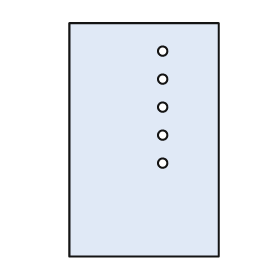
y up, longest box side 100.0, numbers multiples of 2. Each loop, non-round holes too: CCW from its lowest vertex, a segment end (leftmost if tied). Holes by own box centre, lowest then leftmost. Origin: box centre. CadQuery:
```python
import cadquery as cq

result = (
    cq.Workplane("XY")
    .moveTo(-32.0, -50.0)
    .lineTo(32.0, -50.0)
    .lineTo(32.0, 50.0)
    .lineTo(-32.0, 50.0)
    .close()
    .moveTo(8.0, -10.0)
    .circle(2.0)
    .moveTo(8.0, 2.0)
    .circle(2.0)
    .moveTo(8.0, 14.0)
    .circle(2.0)
    .moveTo(8.0, 26.0)
    .circle(2.0)
    .moveTo(8.0, 38.0)
    .circle(2.0)
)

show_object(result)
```